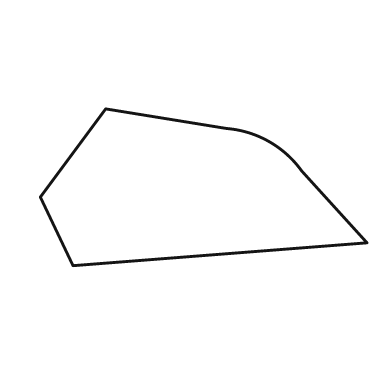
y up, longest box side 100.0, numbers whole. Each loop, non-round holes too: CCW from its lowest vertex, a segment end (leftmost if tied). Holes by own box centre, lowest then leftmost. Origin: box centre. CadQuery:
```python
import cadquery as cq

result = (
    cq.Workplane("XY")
    .moveTo(-40.0, -24.0)
    .lineTo(50.0, -17.0)
    .lineTo(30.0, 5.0)
    .threePointArc((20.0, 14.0), (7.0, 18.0))
    .lineTo(-30.0, 24.0)
    .lineTo(-50.0, -3.0)
    .close()
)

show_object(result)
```